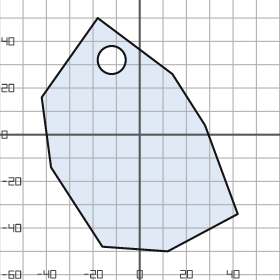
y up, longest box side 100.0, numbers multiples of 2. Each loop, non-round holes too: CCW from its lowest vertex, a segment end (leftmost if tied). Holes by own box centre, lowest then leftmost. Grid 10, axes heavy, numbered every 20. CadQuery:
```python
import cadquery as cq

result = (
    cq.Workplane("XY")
    .moveTo(12.0, -50.0)
    .lineTo(42.0, -34.0)
    .lineTo(28.0, 4.0)
    .lineTo(14.0, 26.0)
    .lineTo(-18.0, 50.0)
    .lineTo(-42.0, 16.0)
    .lineTo(-38.0, -14.0)
    .lineTo(-16.0, -48.0)
    .close()
    .moveTo(-12.0, 32.0)
    .circle(6.0)
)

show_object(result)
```